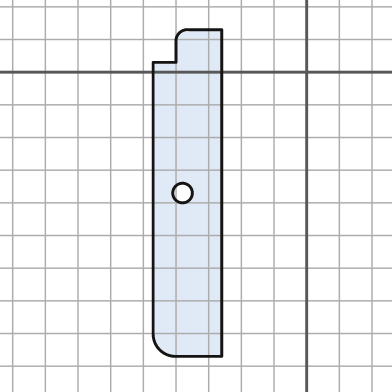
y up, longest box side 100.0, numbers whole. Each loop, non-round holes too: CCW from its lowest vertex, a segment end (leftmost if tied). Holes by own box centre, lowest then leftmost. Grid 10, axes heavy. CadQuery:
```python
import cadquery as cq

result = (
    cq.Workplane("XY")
    .moveTo(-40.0, -87.0)
    .lineTo(-26.0, -87.0)
    .lineTo(-26.0, 13.0)
    .lineTo(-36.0, 13.0)
    .threePointArc((-39.0, 12.0), (-40.0, 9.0))
    .lineTo(-40.0, 3.0)
    .lineTo(-47.0, 3.0)
    .lineTo(-47.0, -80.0)
    .threePointArc((-45.0, -85.0), (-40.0, -87.0))
    .close()
    .moveTo(-38.0, -37.0)
    .circle(3.0)
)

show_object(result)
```